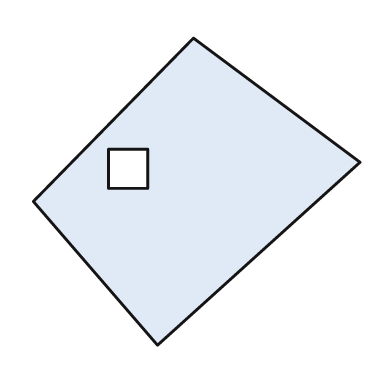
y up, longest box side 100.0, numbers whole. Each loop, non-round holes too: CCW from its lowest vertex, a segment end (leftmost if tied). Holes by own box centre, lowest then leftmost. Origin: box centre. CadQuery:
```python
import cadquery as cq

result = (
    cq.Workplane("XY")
    .moveTo(-12.0, -47.0)
    .lineTo(50.0, 9.0)
    .lineTo(-1.0, 47.0)
    .lineTo(-50.0, -3.0)
    .close()
    .moveTo(-27.0, 1.0)
    .lineTo(-15.0, 1.0)
    .lineTo(-15.0, 13.0)
    .lineTo(-27.0, 13.0)
    .close()
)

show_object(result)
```